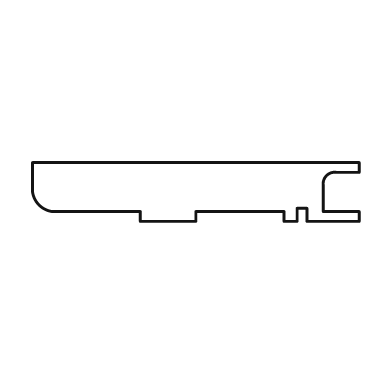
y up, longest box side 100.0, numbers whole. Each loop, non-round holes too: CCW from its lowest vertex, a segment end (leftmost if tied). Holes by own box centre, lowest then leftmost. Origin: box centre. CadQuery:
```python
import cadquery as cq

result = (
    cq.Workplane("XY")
    .moveTo(-17.0, -9.0)
    .lineTo(0.0, -9.0)
    .lineTo(0.0, -6.0)
    .lineTo(27.0, -6.0)
    .lineTo(27.0, -9.0)
    .lineTo(31.0, -9.0)
    .lineTo(31.0, -5.0)
    .lineTo(34.0, -5.0)
    .lineTo(34.0, -9.0)
    .lineTo(50.0, -9.0)
    .lineTo(50.0, -6.0)
    .lineTo(39.0, -6.0)
    .lineTo(39.0, 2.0)
    .threePointArc((40.0, 5.0), (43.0, 6.0))
    .lineTo(50.0, 6.0)
    .lineTo(50.0, 9.0)
    .lineTo(-50.0, 9.0)
    .lineTo(-50.0, 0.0)
    .threePointArc((-48.0, -4.0), (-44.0, -6.0))
    .lineTo(-17.0, -6.0)
    .close()
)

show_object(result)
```